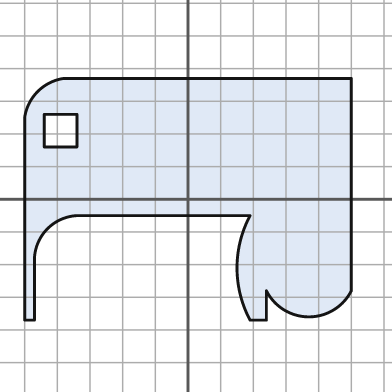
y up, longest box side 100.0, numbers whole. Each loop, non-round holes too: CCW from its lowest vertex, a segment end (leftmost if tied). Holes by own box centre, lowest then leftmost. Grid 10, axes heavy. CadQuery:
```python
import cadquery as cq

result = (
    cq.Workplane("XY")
    .moveTo(-50.0, -37.0)
    .lineTo(-47.0, -37.0)
    .lineTo(-47.0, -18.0)
    .threePointArc((-43.0, -9.0), (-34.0, -5.0))
    .lineTo(19.0, -5.0)
    .threePointArc((15.0, -21.0), (19.0, -37.0))
    .lineTo(24.0, -37.0)
    .lineTo(24.0, -28.0)
    .threePointArc((37.0, -36.0), (50.0, -28.0))
    .lineTo(50.0, 37.0)
    .lineTo(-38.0, 37.0)
    .threePointArc((-46.0, 33.0), (-50.0, 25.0))
    .close()
    .moveTo(-44.0, 16.0)
    .lineTo(-34.0, 16.0)
    .lineTo(-34.0, 26.0)
    .lineTo(-44.0, 26.0)
    .close()
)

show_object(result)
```